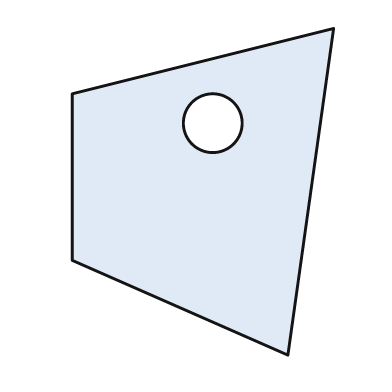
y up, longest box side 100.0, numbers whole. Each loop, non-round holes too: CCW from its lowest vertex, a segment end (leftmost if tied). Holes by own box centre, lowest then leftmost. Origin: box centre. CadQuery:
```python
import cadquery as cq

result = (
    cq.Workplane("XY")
    .moveTo(26.0, -50.0)
    .lineTo(40.0, 50.0)
    .lineTo(-40.0, 30.0)
    .lineTo(-40.0, -21.0)
    .close()
    .moveTo(3.0, 21.0)
    .circle(9.0)
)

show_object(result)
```